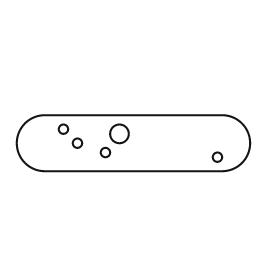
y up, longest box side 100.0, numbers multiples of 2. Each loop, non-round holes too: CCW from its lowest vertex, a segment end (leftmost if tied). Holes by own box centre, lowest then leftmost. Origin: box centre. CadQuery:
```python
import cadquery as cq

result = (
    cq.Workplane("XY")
    .moveTo(-38.0, -12.0)
    .lineTo(38.0, -12.0)
    .threePointArc((50.0, 0.0), (38.0, 12.0))
    .lineTo(-38.0, 12.0)
    .threePointArc((-50.0, 0.0), (-38.0, -12.0))
    .close()
    .moveTo(36.0, -6.0)
    .circle(2.0)
    .moveTo(-12.0, -4.0)
    .circle(2.0)
    .moveTo(-24.0, 0.0)
    .circle(2.0)
    .moveTo(-6.0, 4.0)
    .circle(4.0)
    .moveTo(-30.0, 6.0)
    .circle(2.0)
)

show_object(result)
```